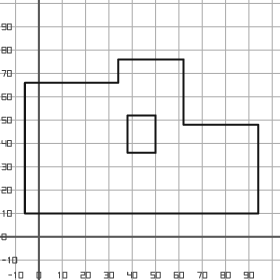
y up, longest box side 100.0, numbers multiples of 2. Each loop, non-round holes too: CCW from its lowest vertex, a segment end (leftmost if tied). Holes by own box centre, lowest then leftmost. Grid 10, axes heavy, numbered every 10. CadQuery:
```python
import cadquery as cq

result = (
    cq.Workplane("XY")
    .moveTo(-6.0, 10.0)
    .lineTo(94.0, 10.0)
    .lineTo(94.0, 48.0)
    .lineTo(62.0, 48.0)
    .lineTo(62.0, 76.0)
    .lineTo(34.0, 76.0)
    .lineTo(34.0, 66.0)
    .lineTo(-6.0, 66.0)
    .close()
    .moveTo(38.0, 36.0)
    .lineTo(50.0, 36.0)
    .lineTo(50.0, 52.0)
    .lineTo(38.0, 52.0)
    .close()
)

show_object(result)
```